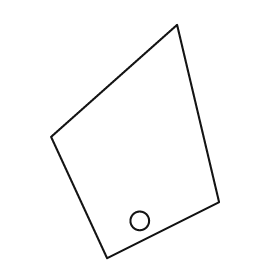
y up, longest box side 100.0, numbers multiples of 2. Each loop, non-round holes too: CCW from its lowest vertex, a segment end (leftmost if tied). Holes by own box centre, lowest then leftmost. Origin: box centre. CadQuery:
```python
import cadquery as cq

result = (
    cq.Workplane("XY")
    .moveTo(-12.0, -50.0)
    .lineTo(36.0, -26.0)
    .lineTo(18.0, 50.0)
    .lineTo(-36.0, 2.0)
    .close()
    .moveTo(2.0, -34.0)
    .circle(4.0)
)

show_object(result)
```